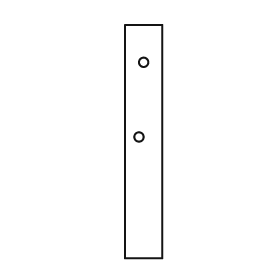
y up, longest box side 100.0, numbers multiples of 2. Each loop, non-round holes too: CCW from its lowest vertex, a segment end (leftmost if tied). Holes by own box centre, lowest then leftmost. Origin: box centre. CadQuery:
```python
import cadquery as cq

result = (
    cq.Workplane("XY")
    .moveTo(-8.0, -50.0)
    .lineTo(8.0, -50.0)
    .lineTo(8.0, 50.0)
    .lineTo(-8.0, 50.0)
    .close()
    .moveTo(-2.0, 2.0)
    .circle(2.0)
    .moveTo(0.0, 34.0)
    .circle(2.0)
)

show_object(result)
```